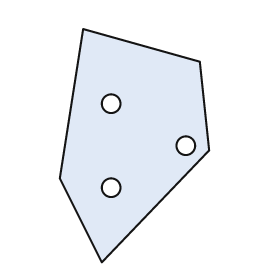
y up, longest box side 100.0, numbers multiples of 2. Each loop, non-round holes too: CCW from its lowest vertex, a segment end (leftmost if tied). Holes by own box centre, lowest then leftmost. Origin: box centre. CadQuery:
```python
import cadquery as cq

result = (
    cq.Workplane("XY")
    .moveTo(-14.0, -50.0)
    .lineTo(32.0, -2.0)
    .lineTo(28.0, 36.0)
    .lineTo(-22.0, 50.0)
    .lineTo(-32.0, -14.0)
    .close()
    .moveTo(-10.0, -18.0)
    .circle(4.0)
    .moveTo(22.0, 0.0)
    .circle(4.0)
    .moveTo(-10.0, 18.0)
    .circle(4.0)
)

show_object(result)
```